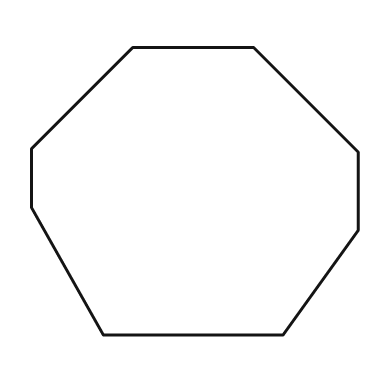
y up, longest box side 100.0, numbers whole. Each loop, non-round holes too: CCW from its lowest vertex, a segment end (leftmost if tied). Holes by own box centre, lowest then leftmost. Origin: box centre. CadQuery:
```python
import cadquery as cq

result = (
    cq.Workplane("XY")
    .moveTo(-28.0, -44.0)
    .lineTo(27.0, -44.0)
    .lineTo(50.0, -12.0)
    .lineTo(50.0, 12.0)
    .lineTo(18.0, 44.0)
    .lineTo(-19.0, 44.0)
    .lineTo(-50.0, 13.0)
    .lineTo(-50.0, -5.0)
    .close()
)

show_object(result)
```